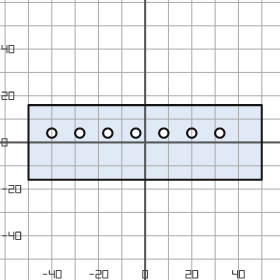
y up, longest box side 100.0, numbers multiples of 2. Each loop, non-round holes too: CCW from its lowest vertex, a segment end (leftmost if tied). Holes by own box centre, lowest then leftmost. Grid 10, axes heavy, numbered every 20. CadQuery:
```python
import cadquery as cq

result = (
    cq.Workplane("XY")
    .moveTo(-50.0, -16.0)
    .lineTo(50.0, -16.0)
    .lineTo(50.0, 16.0)
    .lineTo(-50.0, 16.0)
    .close()
    .moveTo(-40.0, 4.0)
    .circle(2.0)
    .moveTo(-28.0, 4.0)
    .circle(2.0)
    .moveTo(-16.0, 4.0)
    .circle(2.0)
    .moveTo(-4.0, 4.0)
    .circle(2.0)
    .moveTo(8.0, 4.0)
    .circle(2.0)
    .moveTo(20.0, 4.0)
    .circle(2.0)
    .moveTo(32.0, 4.0)
    .circle(2.0)
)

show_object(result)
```